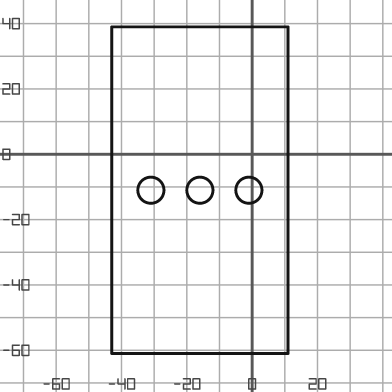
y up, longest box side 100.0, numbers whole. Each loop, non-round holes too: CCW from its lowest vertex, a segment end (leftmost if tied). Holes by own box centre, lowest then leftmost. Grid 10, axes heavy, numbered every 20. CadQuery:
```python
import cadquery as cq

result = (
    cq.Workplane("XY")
    .moveTo(-43.0, -61.0)
    .lineTo(11.0, -61.0)
    .lineTo(11.0, 39.0)
    .lineTo(-43.0, 39.0)
    .close()
    .moveTo(-31.0, -11.0)
    .circle(4.0)
    .moveTo(-16.0, -11.0)
    .circle(4.0)
    .moveTo(-1.0, -11.0)
    .circle(4.0)
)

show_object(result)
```